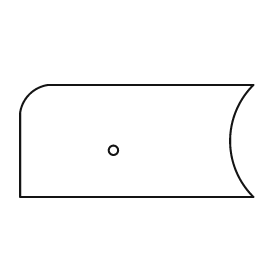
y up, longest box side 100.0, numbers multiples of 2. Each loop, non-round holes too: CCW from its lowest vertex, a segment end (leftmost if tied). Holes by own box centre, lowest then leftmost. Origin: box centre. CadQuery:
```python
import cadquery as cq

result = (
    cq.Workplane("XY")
    .moveTo(-50.0, -24.0)
    .lineTo(50.0, -24.0)
    .threePointArc((40.0, 0.0), (50.0, 24.0))
    .lineTo(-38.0, 24.0)
    .threePointArc((-46.0, 20.0), (-50.0, 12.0))
    .close()
    .moveTo(-10.0, -4.0)
    .circle(2.0)
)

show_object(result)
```